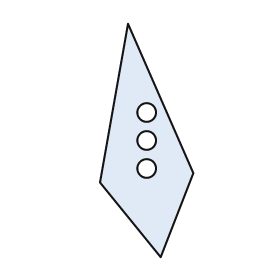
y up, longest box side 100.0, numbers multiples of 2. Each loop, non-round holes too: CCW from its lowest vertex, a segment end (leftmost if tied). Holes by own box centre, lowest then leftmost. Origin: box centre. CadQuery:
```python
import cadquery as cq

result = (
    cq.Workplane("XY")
    .moveTo(6.0, -50.0)
    .lineTo(20.0, -14.0)
    .lineTo(-8.0, 50.0)
    .lineTo(-20.0, -18.0)
    .close()
    .moveTo(0.0, -12.0)
    .circle(4.0)
    .moveTo(0.0, 0.0)
    .circle(4.0)
    .moveTo(0.0, 12.0)
    .circle(4.0)
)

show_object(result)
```